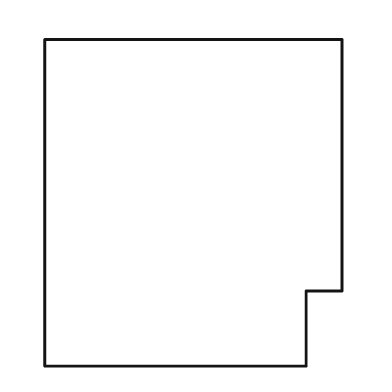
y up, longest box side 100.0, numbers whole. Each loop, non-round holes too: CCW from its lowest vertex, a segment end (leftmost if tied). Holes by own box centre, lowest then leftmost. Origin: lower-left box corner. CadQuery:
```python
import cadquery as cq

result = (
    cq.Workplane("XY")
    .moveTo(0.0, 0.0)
    .lineTo(80.0, 0.0)
    .lineTo(80.0, 23.0)
    .lineTo(91.0, 23.0)
    .lineTo(91.0, 100.0)
    .lineTo(0.0, 100.0)
    .close()
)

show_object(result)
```